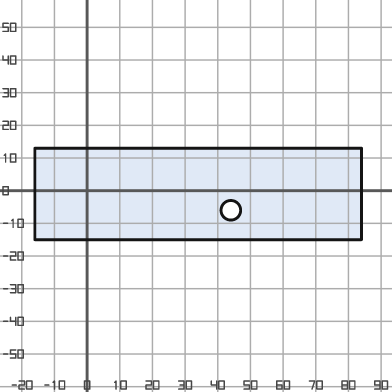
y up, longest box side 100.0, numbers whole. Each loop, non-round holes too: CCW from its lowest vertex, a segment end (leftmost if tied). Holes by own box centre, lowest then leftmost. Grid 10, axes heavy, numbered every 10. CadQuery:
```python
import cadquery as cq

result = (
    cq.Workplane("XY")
    .moveTo(-16.0, -15.0)
    .lineTo(84.0, -15.0)
    .lineTo(84.0, 13.0)
    .lineTo(-16.0, 13.0)
    .close()
    .moveTo(44.0, -6.0)
    .circle(3.0)
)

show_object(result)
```